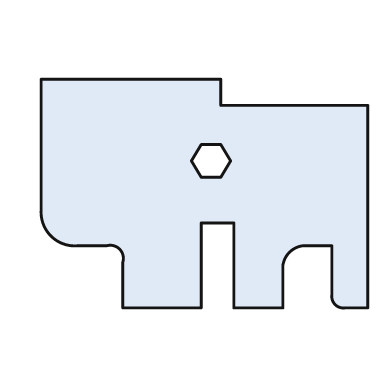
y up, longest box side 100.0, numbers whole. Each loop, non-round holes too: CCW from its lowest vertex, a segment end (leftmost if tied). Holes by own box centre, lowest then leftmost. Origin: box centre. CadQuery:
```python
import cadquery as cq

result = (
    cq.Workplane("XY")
    .moveTo(-25.0, -35.0)
    .lineTo(-1.0, -35.0)
    .lineTo(-1.0, -9.0)
    .lineTo(9.0, -9.0)
    .lineTo(9.0, -35.0)
    .lineTo(24.0, -35.0)
    .lineTo(24.0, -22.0)
    .threePointArc((26.0, -18.0), (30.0, -16.0))
    .lineTo(39.0, -16.0)
    .lineTo(39.0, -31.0)
    .threePointArc((40.0, -34.0), (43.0, -35.0))
    .lineTo(50.0, -35.0)
    .lineTo(50.0, 27.0)
    .lineTo(5.0, 27.0)
    .lineTo(5.0, 35.0)
    .lineTo(-50.0, 35.0)
    .lineTo(-50.0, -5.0)
    .threePointArc((-47.0, -13.0), (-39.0, -16.0))
    .lineTo(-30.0, -16.0)
    .threePointArc((-26.0, -17.0), (-25.0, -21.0))
    .close()
    .moveTo(-1.0, 5.0)
    .lineTo(5.0, 5.0)
    .lineTo(8.0, 10.0)
    .lineTo(5.0, 15.0)
    .lineTo(-1.0, 15.0)
    .lineTo(-4.0, 10.0)
    .close()
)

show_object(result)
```